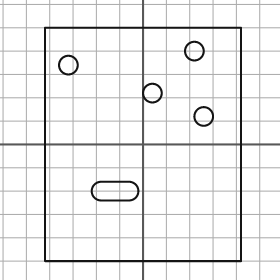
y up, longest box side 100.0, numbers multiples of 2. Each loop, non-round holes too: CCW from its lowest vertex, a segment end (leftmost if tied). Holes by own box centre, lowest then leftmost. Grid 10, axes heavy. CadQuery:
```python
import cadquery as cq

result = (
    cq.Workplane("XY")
    .moveTo(-42.0, -50.0)
    .lineTo(42.0, -50.0)
    .lineTo(42.0, 50.0)
    .lineTo(-42.0, 50.0)
    .close()
    .moveTo(-18.0, -24.0)
    .lineTo(-6.0, -24.0)
    .threePointArc((-2.0, -20.0), (-6.0, -16.0))
    .lineTo(-18.0, -16.0)
    .threePointArc((-22.0, -20.0), (-18.0, -24.0))
    .close()
    .moveTo(26.0, 12.0)
    .circle(4.0)
    .moveTo(4.0, 22.0)
    .circle(4.0)
    .moveTo(-32.0, 34.0)
    .circle(4.0)
    .moveTo(22.0, 40.0)
    .circle(4.0)
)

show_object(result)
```